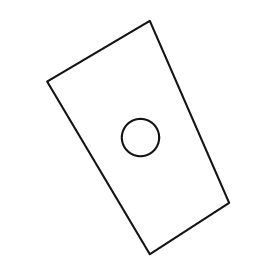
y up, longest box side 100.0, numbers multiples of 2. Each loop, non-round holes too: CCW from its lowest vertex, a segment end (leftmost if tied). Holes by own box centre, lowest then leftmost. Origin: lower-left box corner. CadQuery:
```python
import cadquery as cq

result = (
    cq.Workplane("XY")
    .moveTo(44.0, 0.0)
    .lineTo(78.0, 22.0)
    .lineTo(44.0, 100.0)
    .lineTo(0.0, 74.0)
    .close()
    .moveTo(40.0, 50.0)
    .circle(8.0)
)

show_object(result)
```